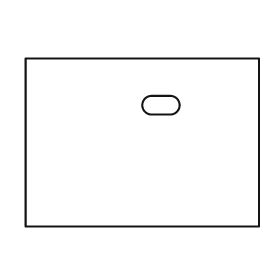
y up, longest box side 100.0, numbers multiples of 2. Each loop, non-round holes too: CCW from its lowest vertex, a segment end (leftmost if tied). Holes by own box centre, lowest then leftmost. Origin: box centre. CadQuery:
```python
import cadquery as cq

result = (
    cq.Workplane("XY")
    .moveTo(-50.0, -36.0)
    .lineTo(50.0, -36.0)
    .lineTo(50.0, 36.0)
    .lineTo(-50.0, 36.0)
    .close()
    .moveTo(4.0, 12.0)
    .lineTo(12.0, 12.0)
    .threePointArc((16.0, 16.0), (12.0, 20.0))
    .lineTo(4.0, 20.0)
    .threePointArc((0.0, 16.0), (4.0, 12.0))
    .close()
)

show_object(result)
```